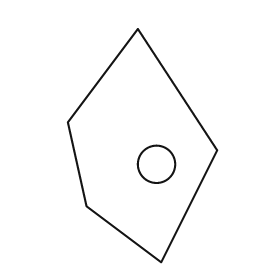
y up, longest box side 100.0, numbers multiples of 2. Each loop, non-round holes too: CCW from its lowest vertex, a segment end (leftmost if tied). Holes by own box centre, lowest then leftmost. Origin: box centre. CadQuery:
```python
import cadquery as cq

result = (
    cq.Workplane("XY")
    .moveTo(8.0, -50.0)
    .lineTo(32.0, -2.0)
    .lineTo(-2.0, 50.0)
    .lineTo(-32.0, 10.0)
    .lineTo(-24.0, -26.0)
    .close()
    .moveTo(6.0, -8.0)
    .circle(8.0)
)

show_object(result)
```